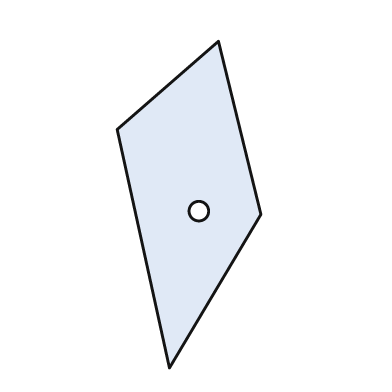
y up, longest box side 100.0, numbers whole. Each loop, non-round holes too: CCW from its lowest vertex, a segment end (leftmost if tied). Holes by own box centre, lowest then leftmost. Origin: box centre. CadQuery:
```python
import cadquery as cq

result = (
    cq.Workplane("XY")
    .moveTo(-6.0, -50.0)
    .lineTo(22.0, -3.0)
    .lineTo(9.0, 50.0)
    .lineTo(-22.0, 23.0)
    .close()
    .moveTo(3.0, -2.0)
    .circle(3.0)
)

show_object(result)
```